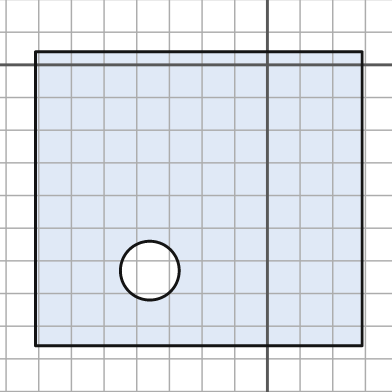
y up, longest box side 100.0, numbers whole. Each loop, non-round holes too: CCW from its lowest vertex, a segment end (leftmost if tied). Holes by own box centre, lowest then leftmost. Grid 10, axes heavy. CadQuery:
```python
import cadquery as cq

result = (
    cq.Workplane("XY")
    .moveTo(-71.0, -86.0)
    .lineTo(29.0, -86.0)
    .lineTo(29.0, 4.0)
    .lineTo(-71.0, 4.0)
    .close()
    .moveTo(-36.0, -63.0)
    .circle(9.0)
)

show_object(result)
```